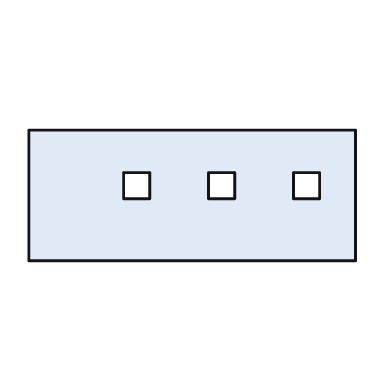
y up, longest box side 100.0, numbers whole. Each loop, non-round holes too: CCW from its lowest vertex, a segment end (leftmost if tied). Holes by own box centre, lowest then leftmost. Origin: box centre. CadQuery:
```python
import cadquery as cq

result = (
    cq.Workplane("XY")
    .moveTo(-50.0, -20.0)
    .lineTo(50.0, -20.0)
    .lineTo(50.0, 20.0)
    .lineTo(-50.0, 20.0)
    .close()
    .moveTo(-21.0, -1.0)
    .lineTo(-13.0, -1.0)
    .lineTo(-13.0, 7.0)
    .lineTo(-21.0, 7.0)
    .close()
    .moveTo(5.0, -1.0)
    .lineTo(13.0, -1.0)
    .lineTo(13.0, 7.0)
    .lineTo(5.0, 7.0)
    .close()
    .moveTo(31.0, -1.0)
    .lineTo(39.0, -1.0)
    .lineTo(39.0, 7.0)
    .lineTo(31.0, 7.0)
    .close()
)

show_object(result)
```